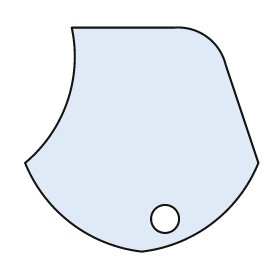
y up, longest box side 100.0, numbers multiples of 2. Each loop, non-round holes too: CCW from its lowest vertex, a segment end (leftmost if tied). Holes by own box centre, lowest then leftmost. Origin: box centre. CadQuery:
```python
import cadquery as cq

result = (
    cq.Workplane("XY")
    .moveTo(0.0, -48.0)
    .threePointArc((30.0, -36.0), (50.0, -10.0))
    .lineTo(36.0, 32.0)
    .threePointArc((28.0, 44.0), (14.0, 48.0))
    .lineTo(-30.0, 48.0)
    .threePointArc((-32.0, 16.0), (-50.0, -10.0))
    .threePointArc((-30.0, -36.0), (0.0, -48.0))
    .close()
    .moveTo(10.0, -34.0)
    .circle(6.0)
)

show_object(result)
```